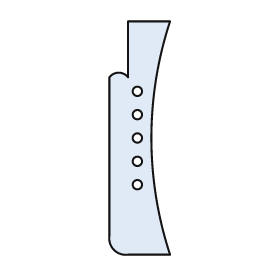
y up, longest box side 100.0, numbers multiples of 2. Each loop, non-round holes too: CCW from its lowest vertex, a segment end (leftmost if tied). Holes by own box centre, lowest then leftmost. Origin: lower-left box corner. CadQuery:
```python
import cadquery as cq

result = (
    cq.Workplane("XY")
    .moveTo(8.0, 0.0)
    .lineTo(26.0, 0.0)
    .threePointArc((18.0, 50.0), (26.0, 100.0))
    .lineTo(8.0, 100.0)
    .lineTo(8.0, 76.0)
    .threePointArc((4.0, 78.0), (0.0, 76.0))
    .lineTo(0.0, 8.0)
    .threePointArc((2.0, 2.0), (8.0, 0.0))
    .close()
    .moveTo(12.0, 30.0)
    .circle(2.0)
    .moveTo(12.0, 40.0)
    .circle(2.0)
    .moveTo(12.0, 50.0)
    .circle(2.0)
    .moveTo(12.0, 60.0)
    .circle(2.0)
    .moveTo(12.0, 70.0)
    .circle(2.0)
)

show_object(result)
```